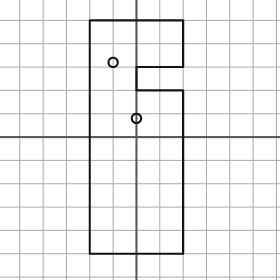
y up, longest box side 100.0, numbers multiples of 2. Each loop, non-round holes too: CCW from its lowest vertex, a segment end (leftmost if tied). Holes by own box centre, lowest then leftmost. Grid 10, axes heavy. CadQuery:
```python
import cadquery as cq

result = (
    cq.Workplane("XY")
    .moveTo(-20.0, -50.0)
    .lineTo(20.0, -50.0)
    .lineTo(20.0, 20.0)
    .lineTo(0.0, 20.0)
    .lineTo(0.0, 30.0)
    .lineTo(20.0, 30.0)
    .lineTo(20.0, 50.0)
    .lineTo(-20.0, 50.0)
    .close()
    .moveTo(0.0, 8.0)
    .circle(2.0)
    .moveTo(-10.0, 32.0)
    .circle(2.0)
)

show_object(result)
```